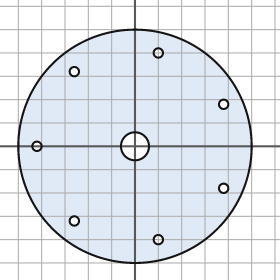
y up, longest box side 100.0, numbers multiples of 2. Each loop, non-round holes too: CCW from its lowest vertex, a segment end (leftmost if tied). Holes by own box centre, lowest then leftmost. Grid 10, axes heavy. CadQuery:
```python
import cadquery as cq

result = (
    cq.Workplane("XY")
    .moveTo(0.0, 0.0)
    .circle(50.0)
    .moveTo(10.0, -40.0)
    .circle(2.0)
    .moveTo(-26.0, -32.0)
    .circle(2.0)
    .moveTo(38.0, -18.0)
    .circle(2.0)
    .moveTo(-42.0, 0.0)
    .circle(2.0)
    .moveTo(0.0, 0.0)
    .circle(6.0)
    .moveTo(38.0, 18.0)
    .circle(2.0)
    .moveTo(-26.0, 32.0)
    .circle(2.0)
    .moveTo(10.0, 40.0)
    .circle(2.0)
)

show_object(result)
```